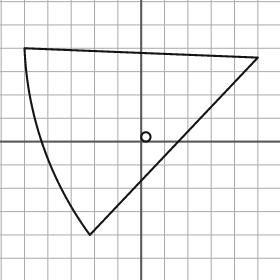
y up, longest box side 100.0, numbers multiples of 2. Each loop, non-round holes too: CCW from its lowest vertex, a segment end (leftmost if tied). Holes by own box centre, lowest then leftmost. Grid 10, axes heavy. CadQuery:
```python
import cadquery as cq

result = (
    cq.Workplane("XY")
    .moveTo(-22.0, -40.0)
    .lineTo(50.0, 36.0)
    .lineTo(-50.0, 40.0)
    .threePointArc((-42.0, -2.0), (-22.0, -40.0))
    .close()
    .moveTo(2.0, 2.0)
    .circle(2.0)
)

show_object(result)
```